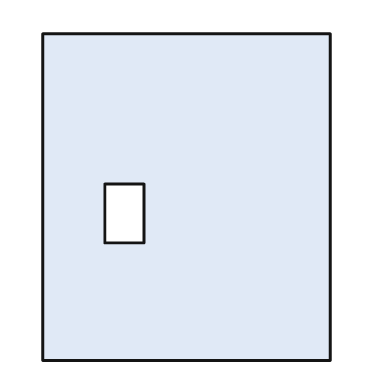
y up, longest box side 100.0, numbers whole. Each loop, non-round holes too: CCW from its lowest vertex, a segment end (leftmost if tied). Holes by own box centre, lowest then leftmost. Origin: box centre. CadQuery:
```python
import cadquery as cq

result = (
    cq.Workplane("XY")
    .moveTo(-44.0, -50.0)
    .lineTo(44.0, -50.0)
    .lineTo(44.0, 50.0)
    .lineTo(-44.0, 50.0)
    .close()
    .moveTo(-25.0, -14.0)
    .lineTo(-13.0, -14.0)
    .lineTo(-13.0, 4.0)
    .lineTo(-25.0, 4.0)
    .close()
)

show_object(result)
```